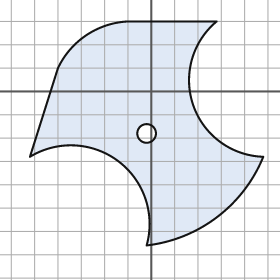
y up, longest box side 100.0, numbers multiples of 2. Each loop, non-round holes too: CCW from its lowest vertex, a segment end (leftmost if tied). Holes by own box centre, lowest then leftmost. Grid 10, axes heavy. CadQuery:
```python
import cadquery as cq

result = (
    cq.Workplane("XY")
    .moveTo(-2.0, -66.0)
    .threePointArc((28.0, -54.0), (48.0, -28.0))
    .threePointArc((18.0, -6.0), (28.0, 30.0))
    .lineTo(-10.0, 30.0)
    .threePointArc((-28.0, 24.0), (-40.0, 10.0))
    .lineTo(-52.0, -28.0)
    .threePointArc((-14.0, -30.0), (-2.0, -66.0))
    .close()
    .moveTo(-2.0, -18.0)
    .circle(4.0)
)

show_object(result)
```